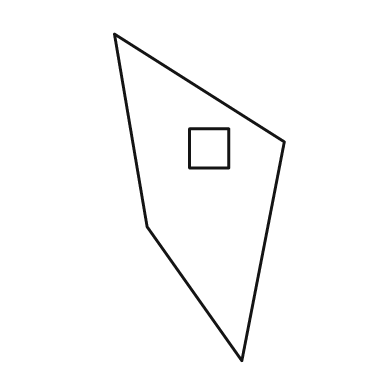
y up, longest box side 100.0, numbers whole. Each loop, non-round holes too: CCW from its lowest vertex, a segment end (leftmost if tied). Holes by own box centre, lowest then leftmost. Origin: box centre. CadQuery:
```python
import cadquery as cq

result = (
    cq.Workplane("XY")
    .moveTo(13.0, -50.0)
    .lineTo(26.0, 17.0)
    .lineTo(-26.0, 50.0)
    .lineTo(-16.0, -9.0)
    .close()
    .moveTo(-3.0, 9.0)
    .lineTo(9.0, 9.0)
    .lineTo(9.0, 21.0)
    .lineTo(-3.0, 21.0)
    .close()
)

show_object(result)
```